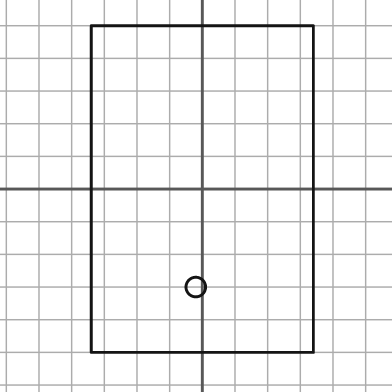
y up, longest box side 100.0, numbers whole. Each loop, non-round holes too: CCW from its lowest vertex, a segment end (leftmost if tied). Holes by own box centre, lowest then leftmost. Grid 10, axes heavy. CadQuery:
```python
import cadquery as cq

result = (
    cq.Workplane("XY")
    .moveTo(-34.0, -50.0)
    .lineTo(34.0, -50.0)
    .lineTo(34.0, 50.0)
    .lineTo(-34.0, 50.0)
    .close()
    .moveTo(-2.0, -30.0)
    .circle(3.0)
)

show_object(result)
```